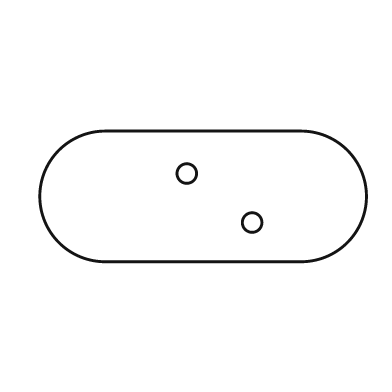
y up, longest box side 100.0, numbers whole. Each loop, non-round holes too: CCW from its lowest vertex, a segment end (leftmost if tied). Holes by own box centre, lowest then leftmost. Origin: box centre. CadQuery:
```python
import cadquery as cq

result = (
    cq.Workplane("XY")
    .moveTo(-30.0, -20.0)
    .lineTo(30.0, -20.0)
    .threePointArc((50.0, 0.0), (30.0, 20.0))
    .lineTo(-30.0, 20.0)
    .threePointArc((-50.0, 0.0), (-30.0, -20.0))
    .close()
    .moveTo(15.0, -8.0)
    .circle(3.0)
    .moveTo(-5.0, 7.0)
    .circle(3.0)
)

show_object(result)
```